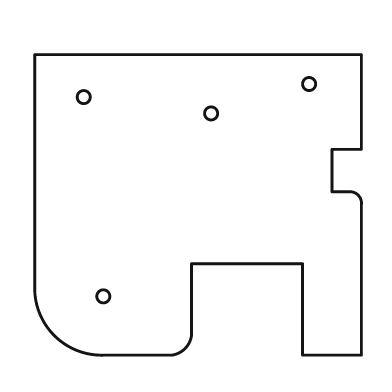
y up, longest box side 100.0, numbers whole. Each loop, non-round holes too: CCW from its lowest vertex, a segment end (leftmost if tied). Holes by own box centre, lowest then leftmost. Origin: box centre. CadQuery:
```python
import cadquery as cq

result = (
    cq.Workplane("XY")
    .moveTo(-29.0, -46.0)
    .lineTo(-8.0, -46.0)
    .threePointArc((-4.0, -44.0), (-2.0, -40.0))
    .lineTo(-2.0, -18.0)
    .lineTo(32.0, -18.0)
    .lineTo(32.0, -46.0)
    .lineTo(50.0, -46.0)
    .lineTo(50.0, 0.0)
    .threePointArc((49.0, 3.0), (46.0, 4.0))
    .lineTo(41.0, 4.0)
    .lineTo(41.0, 17.0)
    .lineTo(50.0, 17.0)
    .lineTo(50.0, 46.0)
    .lineTo(-50.0, 46.0)
    .lineTo(-50.0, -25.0)
    .threePointArc((-44.0, -40.0), (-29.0, -46.0))
    .close()
    .moveTo(-29.0, -28.0)
    .circle(2.0)
    .moveTo(4.0, 28.0)
    .circle(2.0)
    .moveTo(-35.0, 33.0)
    .circle(2.0)
    .moveTo(34.0, 37.0)
    .circle(2.0)
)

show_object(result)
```